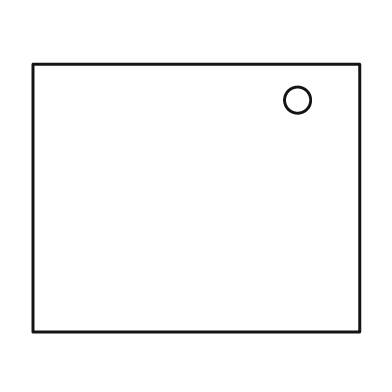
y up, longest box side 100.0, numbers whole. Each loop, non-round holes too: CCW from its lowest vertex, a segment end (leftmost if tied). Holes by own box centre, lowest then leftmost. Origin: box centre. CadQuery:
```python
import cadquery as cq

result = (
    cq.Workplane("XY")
    .moveTo(-50.0, -41.0)
    .lineTo(50.0, -41.0)
    .lineTo(50.0, 41.0)
    .lineTo(-50.0, 41.0)
    .close()
    .moveTo(31.0, 30.0)
    .circle(4.0)
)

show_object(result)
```